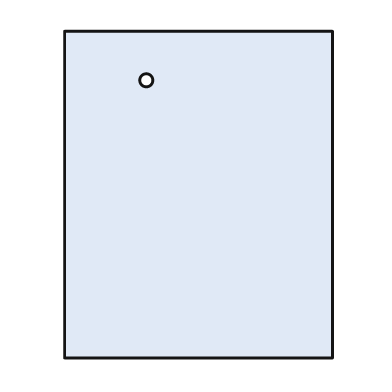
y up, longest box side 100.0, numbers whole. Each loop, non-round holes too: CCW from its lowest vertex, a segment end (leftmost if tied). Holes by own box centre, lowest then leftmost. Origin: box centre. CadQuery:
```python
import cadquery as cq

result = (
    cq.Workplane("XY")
    .moveTo(-41.0, -50.0)
    .lineTo(41.0, -50.0)
    .lineTo(41.0, 50.0)
    .lineTo(-41.0, 50.0)
    .close()
    .moveTo(-16.0, 35.0)
    .circle(2.0)
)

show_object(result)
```